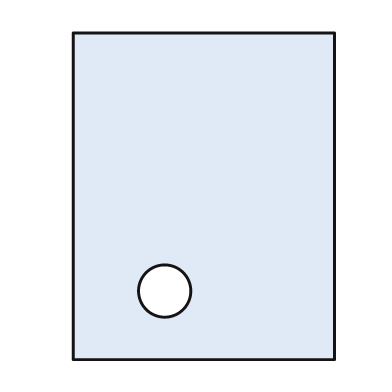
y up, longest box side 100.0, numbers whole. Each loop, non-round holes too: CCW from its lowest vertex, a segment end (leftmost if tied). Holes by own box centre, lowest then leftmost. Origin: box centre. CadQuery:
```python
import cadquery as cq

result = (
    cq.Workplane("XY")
    .moveTo(-40.0, -50.0)
    .lineTo(40.0, -50.0)
    .lineTo(40.0, 50.0)
    .lineTo(-40.0, 50.0)
    .close()
    .moveTo(-12.0, -29.0)
    .circle(8.0)
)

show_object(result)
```